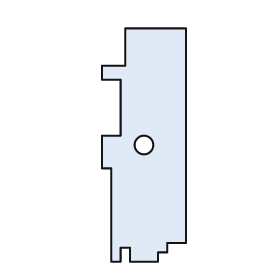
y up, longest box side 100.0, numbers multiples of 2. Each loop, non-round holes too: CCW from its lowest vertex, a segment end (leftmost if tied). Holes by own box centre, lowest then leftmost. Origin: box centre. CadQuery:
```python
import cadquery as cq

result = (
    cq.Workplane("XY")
    .moveTo(-14.0, -50.0)
    .lineTo(-10.0, -50.0)
    .lineTo(-10.0, -44.0)
    .lineTo(-6.0, -44.0)
    .lineTo(-6.0, -50.0)
    .lineTo(6.0, -50.0)
    .lineTo(6.0, -46.0)
    .lineTo(10.0, -46.0)
    .lineTo(10.0, -42.0)
    .lineTo(18.0, -42.0)
    .lineTo(18.0, 50.0)
    .lineTo(-8.0, 50.0)
    .lineTo(-8.0, 34.0)
    .lineTo(-18.0, 34.0)
    .lineTo(-18.0, 28.0)
    .lineTo(-10.0, 28.0)
    .lineTo(-10.0, 4.0)
    .lineTo(-18.0, 4.0)
    .lineTo(-18.0, -10.0)
    .lineTo(-14.0, -10.0)
    .close()
    .moveTo(0.0, 0.0)
    .circle(4.0)
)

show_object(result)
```